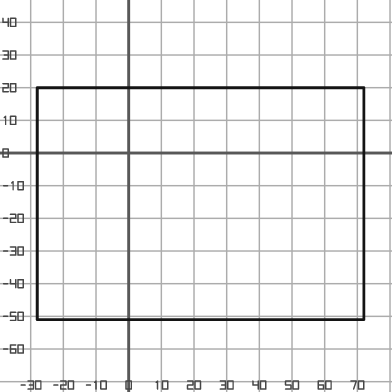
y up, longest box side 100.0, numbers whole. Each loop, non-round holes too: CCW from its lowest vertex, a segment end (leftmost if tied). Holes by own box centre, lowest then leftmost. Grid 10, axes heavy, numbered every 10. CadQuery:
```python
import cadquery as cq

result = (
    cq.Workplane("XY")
    .moveTo(-28.0, -51.0)
    .lineTo(72.0, -51.0)
    .lineTo(72.0, 20.0)
    .lineTo(-28.0, 20.0)
    .close()
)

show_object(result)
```